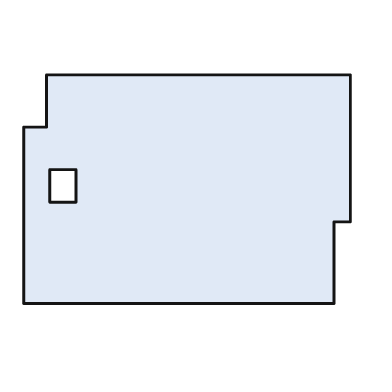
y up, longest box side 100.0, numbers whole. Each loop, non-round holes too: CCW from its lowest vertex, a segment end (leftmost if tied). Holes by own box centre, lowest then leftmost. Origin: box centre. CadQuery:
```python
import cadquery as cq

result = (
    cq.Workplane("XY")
    .moveTo(-50.0, -35.0)
    .lineTo(45.0, -35.0)
    .lineTo(45.0, -10.0)
    .lineTo(50.0, -10.0)
    .lineTo(50.0, 35.0)
    .lineTo(-43.0, 35.0)
    .lineTo(-43.0, 19.0)
    .lineTo(-50.0, 19.0)
    .close()
    .moveTo(-42.0, -4.0)
    .lineTo(-34.0, -4.0)
    .lineTo(-34.0, 6.0)
    .lineTo(-42.0, 6.0)
    .close()
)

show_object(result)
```